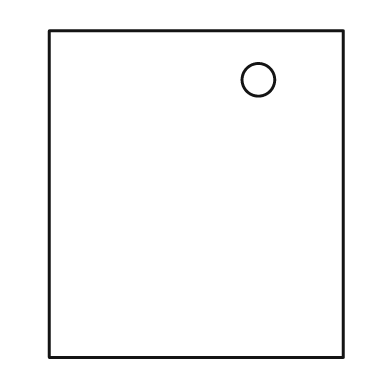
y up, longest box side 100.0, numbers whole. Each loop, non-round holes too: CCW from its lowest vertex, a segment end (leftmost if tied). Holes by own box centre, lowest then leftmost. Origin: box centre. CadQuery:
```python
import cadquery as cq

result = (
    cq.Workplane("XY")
    .moveTo(-45.0, -50.0)
    .lineTo(45.0, -50.0)
    .lineTo(45.0, 50.0)
    .lineTo(-45.0, 50.0)
    .close()
    .moveTo(19.0, 35.0)
    .circle(5.0)
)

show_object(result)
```